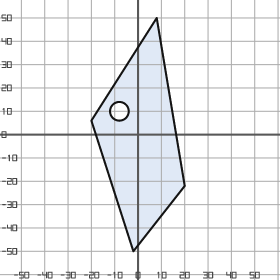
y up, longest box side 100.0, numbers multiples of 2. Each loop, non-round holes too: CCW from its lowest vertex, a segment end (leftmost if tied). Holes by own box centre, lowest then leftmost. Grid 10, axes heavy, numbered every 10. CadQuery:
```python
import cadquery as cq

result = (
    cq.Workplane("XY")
    .moveTo(-2.0, -50.0)
    .lineTo(20.0, -22.0)
    .lineTo(8.0, 50.0)
    .lineTo(-20.0, 6.0)
    .close()
    .moveTo(-8.0, 10.0)
    .circle(4.0)
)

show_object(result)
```